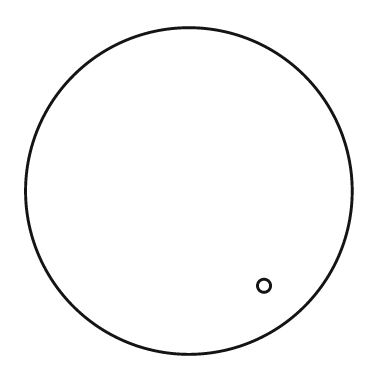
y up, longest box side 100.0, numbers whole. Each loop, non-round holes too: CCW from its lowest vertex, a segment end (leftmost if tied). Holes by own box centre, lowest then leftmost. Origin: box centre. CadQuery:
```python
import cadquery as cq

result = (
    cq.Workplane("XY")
    .moveTo(0.0, 0.0)
    .circle(50.0)
    .moveTo(23.0, -29.0)
    .circle(2.0)
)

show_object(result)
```